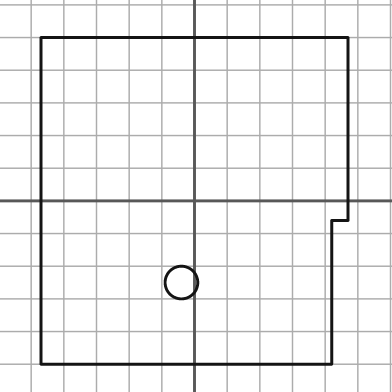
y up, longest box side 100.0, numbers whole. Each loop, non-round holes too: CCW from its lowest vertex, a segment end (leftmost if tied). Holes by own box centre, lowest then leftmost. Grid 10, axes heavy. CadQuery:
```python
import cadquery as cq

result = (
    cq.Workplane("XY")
    .moveTo(-47.0, -50.0)
    .lineTo(42.0, -50.0)
    .lineTo(42.0, -6.0)
    .lineTo(47.0, -6.0)
    .lineTo(47.0, 50.0)
    .lineTo(-47.0, 50.0)
    .close()
    .moveTo(-4.0, -25.0)
    .circle(5.0)
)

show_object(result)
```